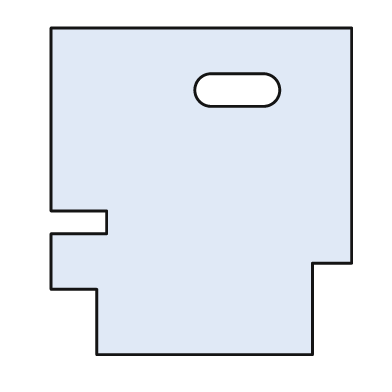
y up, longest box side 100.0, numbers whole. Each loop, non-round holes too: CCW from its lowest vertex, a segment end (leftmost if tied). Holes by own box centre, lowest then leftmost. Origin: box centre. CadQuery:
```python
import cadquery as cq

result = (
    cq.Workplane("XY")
    .moveTo(-32.0, -50.0)
    .lineTo(34.0, -50.0)
    .lineTo(34.0, -22.0)
    .lineTo(46.0, -22.0)
    .lineTo(46.0, 50.0)
    .lineTo(-46.0, 50.0)
    .lineTo(-46.0, -6.0)
    .lineTo(-29.0, -6.0)
    .lineTo(-29.0, -13.0)
    .lineTo(-46.0, -13.0)
    .lineTo(-46.0, -30.0)
    .lineTo(-32.0, -30.0)
    .close()
    .moveTo(3.0, 26.0)
    .lineTo(19.0, 26.0)
    .threePointArc((24.0, 31.0), (19.0, 36.0))
    .lineTo(3.0, 36.0)
    .threePointArc((-2.0, 31.0), (3.0, 26.0))
    .close()
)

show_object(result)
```